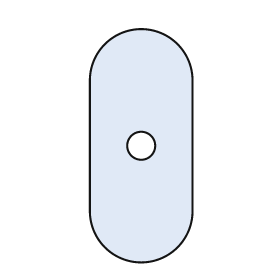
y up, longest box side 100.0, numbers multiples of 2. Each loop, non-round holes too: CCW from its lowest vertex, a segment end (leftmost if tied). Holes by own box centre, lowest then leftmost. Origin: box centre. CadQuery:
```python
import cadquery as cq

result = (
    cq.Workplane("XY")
    .moveTo(-22.0, -28.0)
    .threePointArc((0.0, -50.0), (22.0, -28.0))
    .lineTo(22.0, 28.0)
    .threePointArc((0.0, 50.0), (-22.0, 28.0))
    .close()
    .moveTo(0.0, 0.0)
    .circle(6.0)
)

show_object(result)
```